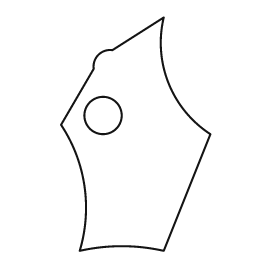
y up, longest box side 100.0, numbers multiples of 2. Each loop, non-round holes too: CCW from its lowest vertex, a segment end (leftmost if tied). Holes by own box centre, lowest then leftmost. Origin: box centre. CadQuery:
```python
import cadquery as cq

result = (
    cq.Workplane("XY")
    .moveTo(-24.0, -50.0)
    .threePointArc((-6.0, -48.0), (12.0, -50.0))
    .lineTo(32.0, 0.0)
    .threePointArc((14.0, 22.0), (12.0, 50.0))
    .lineTo(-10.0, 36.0)
    .threePointArc((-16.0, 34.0), (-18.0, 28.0))
    .lineTo(-32.0, 4.0)
    .threePointArc((-22.0, -22.0), (-24.0, -50.0))
    .close()
    .moveTo(-14.0, 8.0)
    .circle(8.0)
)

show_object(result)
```